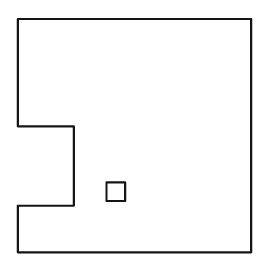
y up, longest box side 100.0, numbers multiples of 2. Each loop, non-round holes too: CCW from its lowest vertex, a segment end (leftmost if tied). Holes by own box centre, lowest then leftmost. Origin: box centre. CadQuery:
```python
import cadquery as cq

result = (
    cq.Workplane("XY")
    .moveTo(-50.0, -50.0)
    .lineTo(50.0, -50.0)
    .lineTo(50.0, 50.0)
    .lineTo(-50.0, 50.0)
    .lineTo(-50.0, 4.0)
    .lineTo(-26.0, 4.0)
    .lineTo(-26.0, -30.0)
    .lineTo(-50.0, -30.0)
    .close()
    .moveTo(-12.0, -28.0)
    .lineTo(-4.0, -28.0)
    .lineTo(-4.0, -20.0)
    .lineTo(-12.0, -20.0)
    .close()
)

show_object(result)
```